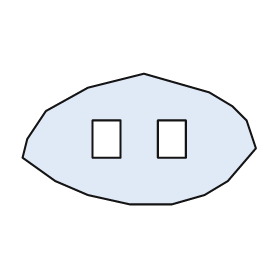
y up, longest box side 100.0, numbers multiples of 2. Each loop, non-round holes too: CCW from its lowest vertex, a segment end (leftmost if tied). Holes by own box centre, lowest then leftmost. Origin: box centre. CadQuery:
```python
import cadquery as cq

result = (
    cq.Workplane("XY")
    .moveTo(-4.0, -28.0)
    .lineTo(14.0, -28.0)
    .lineTo(28.0, -24.0)
    .lineTo(38.0, -18.0)
    .lineTo(50.0, -4.0)
    .lineTo(46.0, 8.0)
    .lineTo(40.0, 14.0)
    .lineTo(30.0, 20.0)
    .lineTo(2.0, 28.0)
    .lineTo(-22.0, 22.0)
    .lineTo(-40.0, 12.0)
    .lineTo(-48.0, 0.0)
    .lineTo(-50.0, -8.0)
    .lineTo(-36.0, -18.0)
    .lineTo(-22.0, -24.0)
    .close()
    .moveTo(-20.0, -8.0)
    .lineTo(-8.0, -8.0)
    .lineTo(-8.0, 8.0)
    .lineTo(-20.0, 8.0)
    .close()
    .moveTo(8.0, -8.0)
    .lineTo(20.0, -8.0)
    .lineTo(20.0, 8.0)
    .lineTo(8.0, 8.0)
    .close()
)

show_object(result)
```